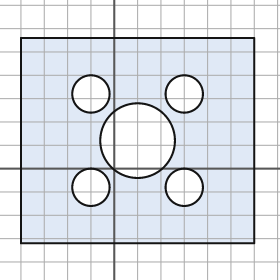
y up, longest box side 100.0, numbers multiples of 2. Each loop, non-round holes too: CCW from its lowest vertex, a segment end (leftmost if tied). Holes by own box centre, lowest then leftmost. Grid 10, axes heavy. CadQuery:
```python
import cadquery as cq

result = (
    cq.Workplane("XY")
    .moveTo(-40.0, -32.0)
    .lineTo(60.0, -32.0)
    .lineTo(60.0, 56.0)
    .lineTo(-40.0, 56.0)
    .close()
    .moveTo(-10.0, -8.0)
    .circle(8.0)
    .moveTo(30.0, -8.0)
    .circle(8.0)
    .moveTo(10.0, 12.0)
    .circle(16.0)
    .moveTo(-10.0, 32.0)
    .circle(8.0)
    .moveTo(30.0, 32.0)
    .circle(8.0)
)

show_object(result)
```